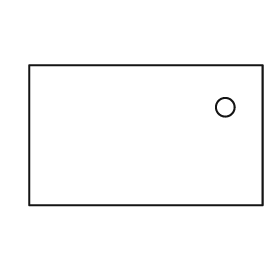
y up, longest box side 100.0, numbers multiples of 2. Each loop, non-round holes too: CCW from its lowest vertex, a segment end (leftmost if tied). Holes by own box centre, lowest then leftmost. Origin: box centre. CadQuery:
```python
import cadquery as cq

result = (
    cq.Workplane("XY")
    .moveTo(-50.0, -30.0)
    .lineTo(50.0, -30.0)
    .lineTo(50.0, 30.0)
    .lineTo(-50.0, 30.0)
    .close()
    .moveTo(34.0, 12.0)
    .circle(4.0)
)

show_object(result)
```